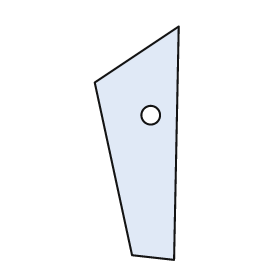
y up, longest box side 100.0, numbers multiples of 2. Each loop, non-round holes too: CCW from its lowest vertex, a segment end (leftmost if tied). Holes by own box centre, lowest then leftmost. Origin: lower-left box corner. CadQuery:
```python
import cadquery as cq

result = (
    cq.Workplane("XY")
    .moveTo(34.0, 0.0)
    .lineTo(36.0, 100.0)
    .lineTo(0.0, 76.0)
    .lineTo(16.0, 2.0)
    .close()
    .moveTo(24.0, 62.0)
    .circle(4.0)
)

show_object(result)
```